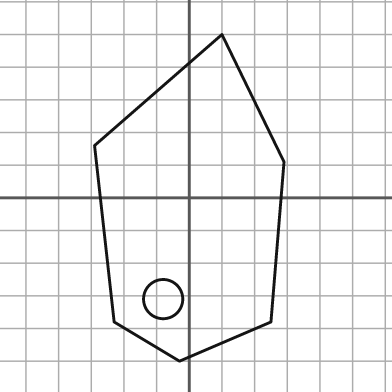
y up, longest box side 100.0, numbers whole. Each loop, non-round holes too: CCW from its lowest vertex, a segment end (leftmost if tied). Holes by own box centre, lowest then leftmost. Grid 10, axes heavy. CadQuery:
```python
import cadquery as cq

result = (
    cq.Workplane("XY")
    .moveTo(-3.0, -50.0)
    .lineTo(25.0, -38.0)
    .lineTo(29.0, 11.0)
    .lineTo(10.0, 50.0)
    .lineTo(-29.0, 16.0)
    .lineTo(-23.0, -38.0)
    .close()
    .moveTo(-8.0, -31.0)
    .circle(6.0)
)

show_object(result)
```